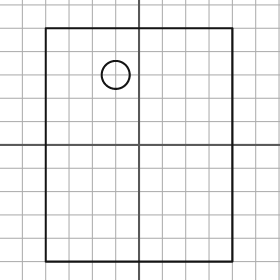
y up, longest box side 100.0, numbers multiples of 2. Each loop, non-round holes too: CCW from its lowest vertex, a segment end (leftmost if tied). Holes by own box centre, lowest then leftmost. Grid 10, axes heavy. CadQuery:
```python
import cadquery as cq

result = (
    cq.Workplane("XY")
    .moveTo(-40.0, -50.0)
    .lineTo(40.0, -50.0)
    .lineTo(40.0, 50.0)
    .lineTo(-40.0, 50.0)
    .close()
    .moveTo(-10.0, 30.0)
    .circle(6.0)
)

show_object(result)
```